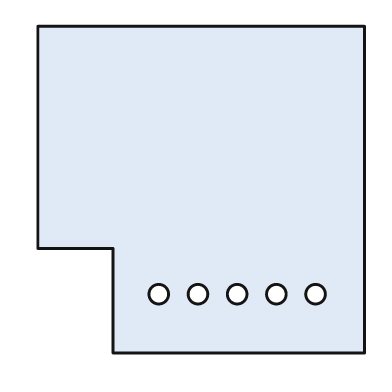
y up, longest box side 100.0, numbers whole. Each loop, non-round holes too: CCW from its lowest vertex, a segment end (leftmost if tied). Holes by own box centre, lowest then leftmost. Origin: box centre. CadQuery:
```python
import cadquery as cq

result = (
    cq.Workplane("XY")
    .moveTo(-27.0, -50.0)
    .lineTo(50.0, -50.0)
    .lineTo(50.0, 50.0)
    .lineTo(-50.0, 50.0)
    .lineTo(-50.0, -18.0)
    .lineTo(-27.0, -18.0)
    .close()
    .moveTo(-13.0, -32.0)
    .circle(3.0)
    .moveTo(-1.0, -32.0)
    .circle(3.0)
    .moveTo(11.0, -32.0)
    .circle(3.0)
    .moveTo(23.0, -32.0)
    .circle(3.0)
    .moveTo(35.0, -32.0)
    .circle(3.0)
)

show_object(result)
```